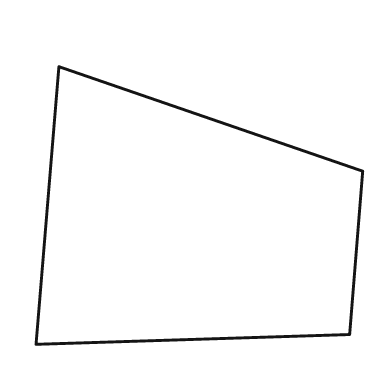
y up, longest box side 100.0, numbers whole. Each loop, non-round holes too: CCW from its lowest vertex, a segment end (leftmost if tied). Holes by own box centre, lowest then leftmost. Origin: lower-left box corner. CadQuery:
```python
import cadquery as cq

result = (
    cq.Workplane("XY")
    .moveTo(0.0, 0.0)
    .lineTo(96.0, 3.0)
    .lineTo(100.0, 53.0)
    .lineTo(7.0, 85.0)
    .close()
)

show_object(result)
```